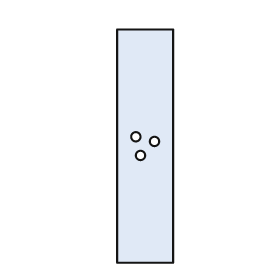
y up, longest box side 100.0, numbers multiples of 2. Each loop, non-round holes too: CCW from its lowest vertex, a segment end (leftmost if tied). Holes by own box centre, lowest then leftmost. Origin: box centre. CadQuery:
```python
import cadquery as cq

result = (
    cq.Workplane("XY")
    .moveTo(-12.0, -50.0)
    .lineTo(12.0, -50.0)
    .lineTo(12.0, 50.0)
    .lineTo(-12.0, 50.0)
    .close()
    .moveTo(-2.0, -4.0)
    .circle(2.0)
    .moveTo(4.0, 2.0)
    .circle(2.0)
    .moveTo(-4.0, 4.0)
    .circle(2.0)
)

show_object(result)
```